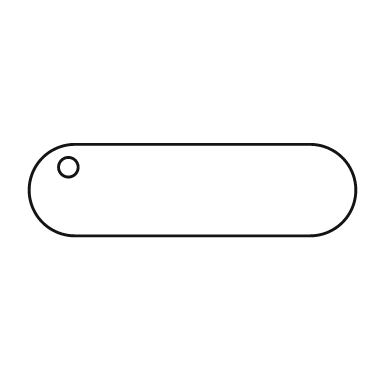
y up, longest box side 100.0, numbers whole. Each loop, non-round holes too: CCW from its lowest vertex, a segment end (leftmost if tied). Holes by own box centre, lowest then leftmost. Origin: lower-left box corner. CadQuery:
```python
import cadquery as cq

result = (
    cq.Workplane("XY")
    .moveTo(14.0, 0.0)
    .lineTo(86.0, 0.0)
    .threePointArc((100.0, 14.0), (86.0, 28.0))
    .lineTo(14.0, 28.0)
    .threePointArc((0.0, 14.0), (14.0, 0.0))
    .close()
    .moveTo(12.0, 21.0)
    .circle(3.0)
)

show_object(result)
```